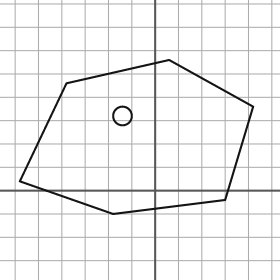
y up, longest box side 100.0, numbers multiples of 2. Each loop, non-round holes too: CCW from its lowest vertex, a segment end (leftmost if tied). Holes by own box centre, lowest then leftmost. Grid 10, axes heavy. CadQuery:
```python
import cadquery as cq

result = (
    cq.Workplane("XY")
    .moveTo(-18.0, -10.0)
    .lineTo(30.0, -4.0)
    .lineTo(42.0, 36.0)
    .lineTo(6.0, 56.0)
    .lineTo(-38.0, 46.0)
    .lineTo(-58.0, 4.0)
    .close()
    .moveTo(-14.0, 32.0)
    .circle(4.0)
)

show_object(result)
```